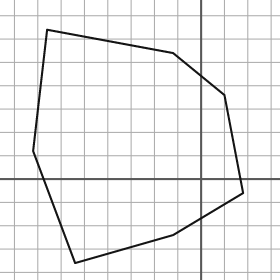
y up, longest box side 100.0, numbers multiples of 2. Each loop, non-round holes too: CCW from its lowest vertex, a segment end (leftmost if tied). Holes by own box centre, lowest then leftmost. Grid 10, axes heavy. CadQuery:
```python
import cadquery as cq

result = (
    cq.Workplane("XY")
    .moveTo(-54.0, -36.0)
    .lineTo(-12.0, -24.0)
    .lineTo(18.0, -6.0)
    .lineTo(10.0, 36.0)
    .lineTo(-12.0, 54.0)
    .lineTo(-66.0, 64.0)
    .lineTo(-72.0, 12.0)
    .close()
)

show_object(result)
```